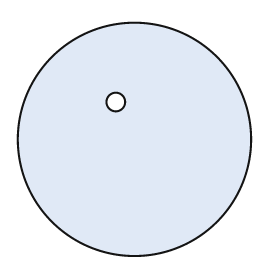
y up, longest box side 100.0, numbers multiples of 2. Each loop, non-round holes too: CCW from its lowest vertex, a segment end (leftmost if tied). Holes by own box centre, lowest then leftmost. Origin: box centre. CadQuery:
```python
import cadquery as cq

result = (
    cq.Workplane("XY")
    .moveTo(0.0, 0.0)
    .circle(50.0)
    .moveTo(-8.0, 16.0)
    .circle(4.0)
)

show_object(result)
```